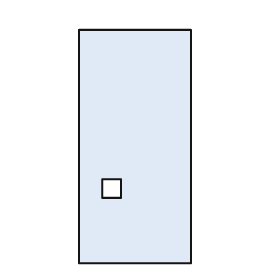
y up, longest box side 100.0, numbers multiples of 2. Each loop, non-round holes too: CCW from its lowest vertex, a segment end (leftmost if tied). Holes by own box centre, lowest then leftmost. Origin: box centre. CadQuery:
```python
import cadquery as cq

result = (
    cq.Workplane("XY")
    .moveTo(-24.0, -50.0)
    .lineTo(24.0, -50.0)
    .lineTo(24.0, 50.0)
    .lineTo(-24.0, 50.0)
    .close()
    .moveTo(-14.0, -22.0)
    .lineTo(-6.0, -22.0)
    .lineTo(-6.0, -14.0)
    .lineTo(-14.0, -14.0)
    .close()
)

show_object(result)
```